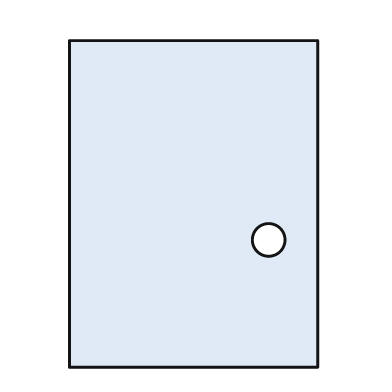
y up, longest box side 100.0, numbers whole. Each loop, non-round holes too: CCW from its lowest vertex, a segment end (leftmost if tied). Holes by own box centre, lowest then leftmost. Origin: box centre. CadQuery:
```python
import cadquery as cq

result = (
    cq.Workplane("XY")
    .moveTo(-38.0, -50.0)
    .lineTo(38.0, -50.0)
    .lineTo(38.0, 50.0)
    .lineTo(-38.0, 50.0)
    .close()
    .moveTo(23.0, -11.0)
    .circle(5.0)
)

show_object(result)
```